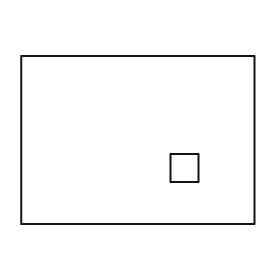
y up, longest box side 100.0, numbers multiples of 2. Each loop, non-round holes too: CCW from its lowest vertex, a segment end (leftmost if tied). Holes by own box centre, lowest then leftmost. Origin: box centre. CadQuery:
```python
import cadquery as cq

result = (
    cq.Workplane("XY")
    .moveTo(-50.0, -36.0)
    .lineTo(50.0, -36.0)
    .lineTo(50.0, 36.0)
    .lineTo(-50.0, 36.0)
    .close()
    .moveTo(14.0, -18.0)
    .lineTo(26.0, -18.0)
    .lineTo(26.0, -6.0)
    .lineTo(14.0, -6.0)
    .close()
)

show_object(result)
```